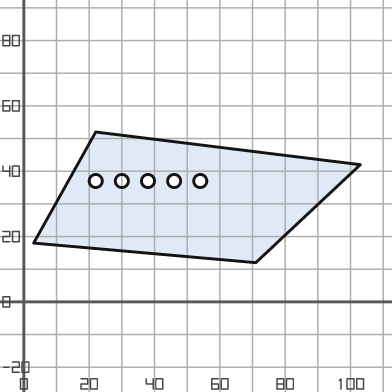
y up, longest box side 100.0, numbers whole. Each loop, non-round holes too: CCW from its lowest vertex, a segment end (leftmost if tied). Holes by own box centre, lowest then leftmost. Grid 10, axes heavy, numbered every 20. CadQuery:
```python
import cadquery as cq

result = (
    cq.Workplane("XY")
    .moveTo(71.0, 12.0)
    .lineTo(103.0, 42.0)
    .lineTo(22.0, 52.0)
    .lineTo(3.0, 18.0)
    .close()
    .moveTo(22.0, 37.0)
    .circle(2.0)
    .moveTo(30.0, 37.0)
    .circle(2.0)
    .moveTo(38.0, 37.0)
    .circle(2.0)
    .moveTo(46.0, 37.0)
    .circle(2.0)
    .moveTo(54.0, 37.0)
    .circle(2.0)
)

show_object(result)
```